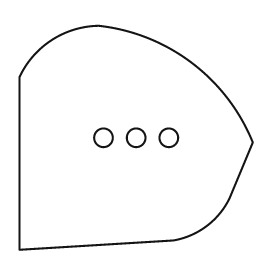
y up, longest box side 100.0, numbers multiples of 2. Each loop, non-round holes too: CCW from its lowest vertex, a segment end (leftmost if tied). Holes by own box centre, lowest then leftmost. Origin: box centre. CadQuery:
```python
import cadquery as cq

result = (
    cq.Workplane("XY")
    .moveTo(-50.0, -48.0)
    .lineTo(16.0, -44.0)
    .threePointArc((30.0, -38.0), (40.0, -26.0))
    .lineTo(50.0, -2.0)
    .threePointArc((24.0, 32.0), (-16.0, 48.0))
    .threePointArc((-36.0, 42.0), (-50.0, 26.0))
    .close()
    .moveTo(-14.0, 0.0)
    .circle(4.0)
    .moveTo(0.0, 0.0)
    .circle(4.0)
    .moveTo(14.0, 0.0)
    .circle(4.0)
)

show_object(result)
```